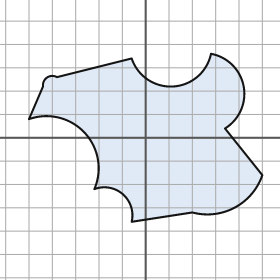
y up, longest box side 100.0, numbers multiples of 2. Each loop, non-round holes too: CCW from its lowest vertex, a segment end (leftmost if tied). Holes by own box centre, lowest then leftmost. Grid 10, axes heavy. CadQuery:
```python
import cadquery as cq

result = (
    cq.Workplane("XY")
    .moveTo(-6.0, -36.0)
    .lineTo(20.0, -32.0)
    .threePointArc((38.0, -30.0), (50.0, -16.0))
    .lineTo(34.0, 4.0)
    .threePointArc((42.0, 22.0), (28.0, 36.0))
    .threePointArc((12.0, 22.0), (-6.0, 34.0))
    .lineTo(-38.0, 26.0)
    .threePointArc((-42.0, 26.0), (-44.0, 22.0))
    .lineTo(-50.0, 8.0)
    .threePointArc((-26.0, 2.0), (-22.0, -22.0))
    .threePointArc((-10.0, -24.0), (-6.0, -36.0))
    .close()
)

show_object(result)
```